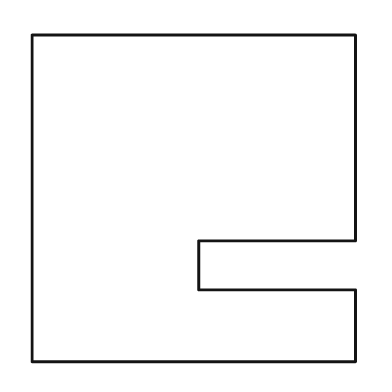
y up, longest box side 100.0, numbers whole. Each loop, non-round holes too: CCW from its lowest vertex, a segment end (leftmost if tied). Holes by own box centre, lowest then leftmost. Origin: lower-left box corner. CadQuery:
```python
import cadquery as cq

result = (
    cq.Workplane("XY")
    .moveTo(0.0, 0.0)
    .lineTo(99.0, 0.0)
    .lineTo(99.0, 22.0)
    .lineTo(51.0, 22.0)
    .lineTo(51.0, 37.0)
    .lineTo(99.0, 37.0)
    .lineTo(99.0, 100.0)
    .lineTo(0.0, 100.0)
    .close()
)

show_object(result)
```